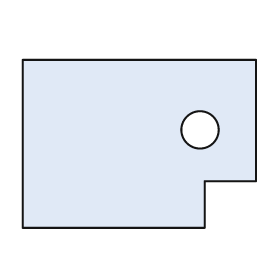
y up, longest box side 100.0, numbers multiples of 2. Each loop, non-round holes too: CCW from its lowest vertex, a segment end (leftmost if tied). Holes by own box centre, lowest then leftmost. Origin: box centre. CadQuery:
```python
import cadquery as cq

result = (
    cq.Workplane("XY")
    .moveTo(-50.0, -36.0)
    .lineTo(28.0, -36.0)
    .lineTo(28.0, -16.0)
    .lineTo(50.0, -16.0)
    .lineTo(50.0, 36.0)
    .lineTo(-50.0, 36.0)
    .close()
    .moveTo(26.0, 6.0)
    .circle(8.0)
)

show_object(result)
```